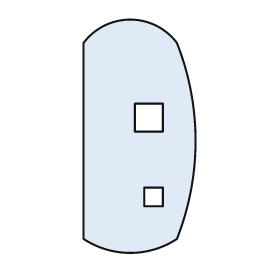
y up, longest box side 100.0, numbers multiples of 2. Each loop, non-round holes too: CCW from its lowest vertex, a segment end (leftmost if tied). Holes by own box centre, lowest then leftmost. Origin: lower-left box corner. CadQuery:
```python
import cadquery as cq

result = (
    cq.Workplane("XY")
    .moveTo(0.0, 6.0)
    .threePointArc((20.0, 0.0), (40.0, 6.0))
    .threePointArc((48.0, 48.0), (40.0, 90.0))
    .threePointArc((20.0, 100.0), (0.0, 90.0))
    .close()
    .moveTo(26.0, 20.0)
    .lineTo(34.0, 20.0)
    .lineTo(34.0, 28.0)
    .lineTo(26.0, 28.0)
    .close()
    .moveTo(22.0, 52.0)
    .lineTo(34.0, 52.0)
    .lineTo(34.0, 64.0)
    .lineTo(22.0, 64.0)
    .close()
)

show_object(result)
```